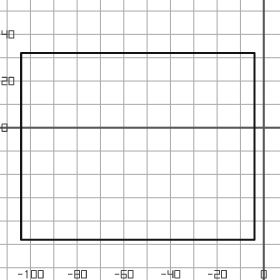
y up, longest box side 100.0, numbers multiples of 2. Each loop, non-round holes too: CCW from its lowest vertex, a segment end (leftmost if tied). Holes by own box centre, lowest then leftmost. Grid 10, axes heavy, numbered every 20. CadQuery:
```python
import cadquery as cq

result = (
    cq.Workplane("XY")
    .moveTo(-104.0, -48.0)
    .lineTo(-4.0, -48.0)
    .lineTo(-4.0, 32.0)
    .lineTo(-104.0, 32.0)
    .close()
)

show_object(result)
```